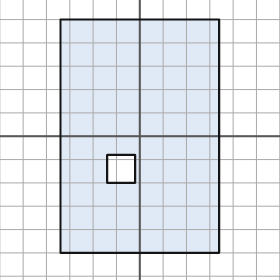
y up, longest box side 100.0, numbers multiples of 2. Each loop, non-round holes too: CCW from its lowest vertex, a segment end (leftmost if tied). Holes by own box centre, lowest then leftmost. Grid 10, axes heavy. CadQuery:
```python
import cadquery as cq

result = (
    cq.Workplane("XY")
    .moveTo(-34.0, -50.0)
    .lineTo(34.0, -50.0)
    .lineTo(34.0, 50.0)
    .lineTo(-34.0, 50.0)
    .close()
    .moveTo(-14.0, -20.0)
    .lineTo(-2.0, -20.0)
    .lineTo(-2.0, -8.0)
    .lineTo(-14.0, -8.0)
    .close()
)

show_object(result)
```